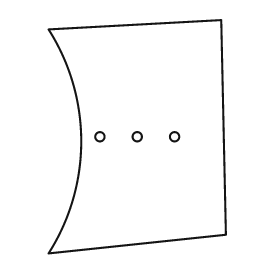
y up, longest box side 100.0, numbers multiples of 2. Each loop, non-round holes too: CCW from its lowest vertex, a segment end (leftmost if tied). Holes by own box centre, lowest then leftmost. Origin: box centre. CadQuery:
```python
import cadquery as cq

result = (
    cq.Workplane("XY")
    .moveTo(-38.0, -50.0)
    .lineTo(38.0, -42.0)
    .lineTo(36.0, 50.0)
    .lineTo(-38.0, 46.0)
    .threePointArc((-24.0, -2.0), (-38.0, -50.0))
    .close()
    .moveTo(-16.0, 0.0)
    .circle(2.0)
    .moveTo(0.0, 0.0)
    .circle(2.0)
    .moveTo(16.0, 0.0)
    .circle(2.0)
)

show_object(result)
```